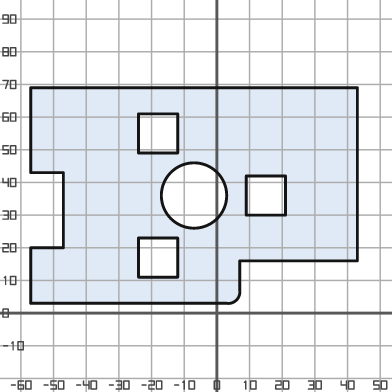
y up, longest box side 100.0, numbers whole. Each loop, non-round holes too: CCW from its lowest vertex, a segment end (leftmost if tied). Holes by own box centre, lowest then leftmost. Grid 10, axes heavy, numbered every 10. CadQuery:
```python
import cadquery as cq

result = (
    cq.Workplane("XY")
    .moveTo(-57.0, 3.0)
    .lineTo(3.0, 3.0)
    .threePointArc((6.0, 4.0), (7.0, 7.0))
    .lineTo(7.0, 16.0)
    .lineTo(43.0, 16.0)
    .lineTo(43.0, 69.0)
    .lineTo(-57.0, 69.0)
    .lineTo(-57.0, 43.0)
    .lineTo(-47.0, 43.0)
    .lineTo(-47.0, 20.0)
    .lineTo(-57.0, 20.0)
    .close()
    .moveTo(-24.0, 11.0)
    .lineTo(-12.0, 11.0)
    .lineTo(-12.0, 23.0)
    .lineTo(-24.0, 23.0)
    .close()
    .moveTo(-7.0, 36.0)
    .circle(10.0)
    .moveTo(9.0, 30.0)
    .lineTo(21.0, 30.0)
    .lineTo(21.0, 42.0)
    .lineTo(9.0, 42.0)
    .close()
    .moveTo(-24.0, 49.0)
    .lineTo(-12.0, 49.0)
    .lineTo(-12.0, 61.0)
    .lineTo(-24.0, 61.0)
    .close()
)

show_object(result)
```